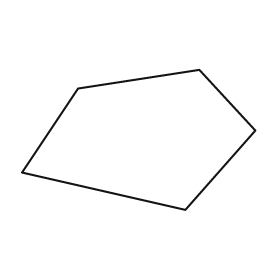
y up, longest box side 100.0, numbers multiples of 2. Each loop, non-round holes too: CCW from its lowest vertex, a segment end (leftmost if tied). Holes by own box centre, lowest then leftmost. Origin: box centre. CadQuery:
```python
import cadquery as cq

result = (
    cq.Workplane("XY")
    .moveTo(20.0, -30.0)
    .lineTo(50.0, 4.0)
    .lineTo(26.0, 30.0)
    .lineTo(-26.0, 22.0)
    .lineTo(-50.0, -14.0)
    .close()
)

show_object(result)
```